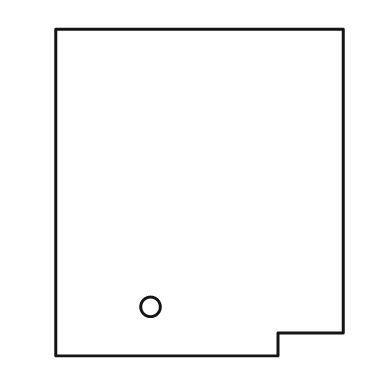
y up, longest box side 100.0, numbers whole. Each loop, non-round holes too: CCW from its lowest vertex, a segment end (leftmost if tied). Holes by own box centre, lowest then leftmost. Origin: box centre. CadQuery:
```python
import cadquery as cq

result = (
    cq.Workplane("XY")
    .moveTo(-44.0, -50.0)
    .lineTo(24.0, -50.0)
    .lineTo(24.0, -43.0)
    .lineTo(44.0, -43.0)
    .lineTo(44.0, 50.0)
    .lineTo(-44.0, 50.0)
    .close()
    .moveTo(-15.0, -35.0)
    .circle(3.0)
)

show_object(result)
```